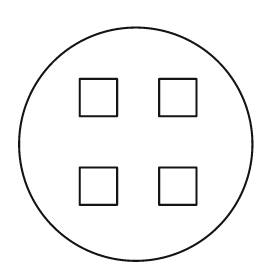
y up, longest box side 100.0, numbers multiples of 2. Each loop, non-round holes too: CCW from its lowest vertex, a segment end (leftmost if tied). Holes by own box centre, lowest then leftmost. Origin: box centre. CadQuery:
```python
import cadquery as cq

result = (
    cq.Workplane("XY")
    .moveTo(0.0, 0.0)
    .circle(50.0)
    .moveTo(-24.0, -26.0)
    .lineTo(-8.0, -26.0)
    .lineTo(-8.0, -10.0)
    .lineTo(-24.0, -10.0)
    .close()
    .moveTo(10.0, -26.0)
    .lineTo(26.0, -26.0)
    .lineTo(26.0, -10.0)
    .lineTo(10.0, -10.0)
    .close()
    .moveTo(-24.0, 12.0)
    .lineTo(-8.0, 12.0)
    .lineTo(-8.0, 28.0)
    .lineTo(-24.0, 28.0)
    .close()
    .moveTo(10.0, 12.0)
    .lineTo(26.0, 12.0)
    .lineTo(26.0, 28.0)
    .lineTo(10.0, 28.0)
    .close()
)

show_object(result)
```